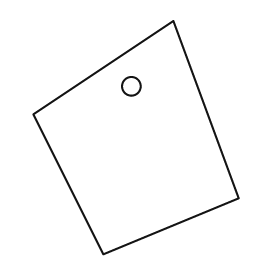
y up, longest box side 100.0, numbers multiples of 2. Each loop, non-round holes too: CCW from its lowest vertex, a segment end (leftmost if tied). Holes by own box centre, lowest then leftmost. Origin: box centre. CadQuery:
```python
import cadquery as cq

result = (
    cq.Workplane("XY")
    .moveTo(-14.0, -50.0)
    .lineTo(44.0, -26.0)
    .lineTo(16.0, 50.0)
    .lineTo(-44.0, 10.0)
    .close()
    .moveTo(-2.0, 22.0)
    .circle(4.0)
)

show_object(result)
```